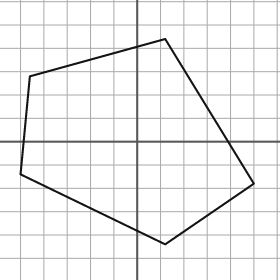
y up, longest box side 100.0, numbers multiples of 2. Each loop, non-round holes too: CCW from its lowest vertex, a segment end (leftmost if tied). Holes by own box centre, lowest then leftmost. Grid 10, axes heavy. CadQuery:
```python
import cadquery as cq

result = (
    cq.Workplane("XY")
    .moveTo(12.0, -44.0)
    .lineTo(50.0, -18.0)
    .lineTo(12.0, 44.0)
    .lineTo(-46.0, 28.0)
    .lineTo(-50.0, -14.0)
    .close()
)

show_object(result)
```